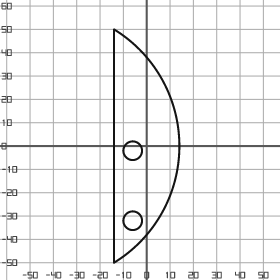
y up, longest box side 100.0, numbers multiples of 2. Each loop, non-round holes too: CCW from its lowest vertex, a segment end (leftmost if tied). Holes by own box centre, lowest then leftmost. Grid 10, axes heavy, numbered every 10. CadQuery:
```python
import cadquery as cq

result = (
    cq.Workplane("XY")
    .moveTo(-14.0, -50.0)
    .threePointArc((14.0, 0.0), (-14.0, 50.0))
    .close()
    .moveTo(-6.0, -32.0)
    .circle(4.0)
    .moveTo(-6.0, -2.0)
    .circle(4.0)
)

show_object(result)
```